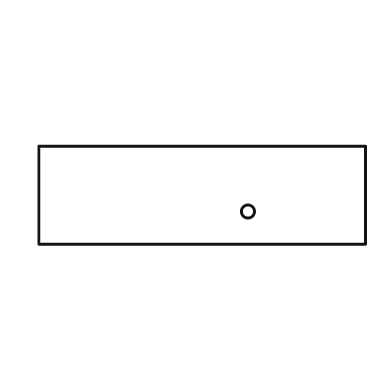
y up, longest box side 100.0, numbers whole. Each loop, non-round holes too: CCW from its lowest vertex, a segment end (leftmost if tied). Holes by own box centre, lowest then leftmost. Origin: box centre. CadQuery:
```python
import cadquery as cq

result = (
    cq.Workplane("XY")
    .moveTo(-50.0, -15.0)
    .lineTo(50.0, -15.0)
    .lineTo(50.0, 15.0)
    .lineTo(-50.0, 15.0)
    .close()
    .moveTo(14.0, -5.0)
    .circle(2.0)
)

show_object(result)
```